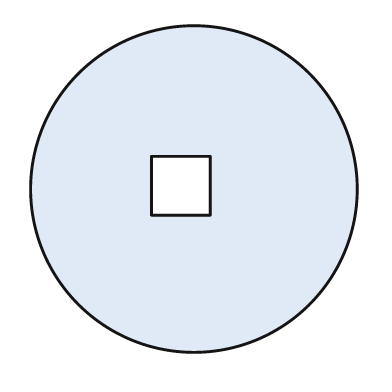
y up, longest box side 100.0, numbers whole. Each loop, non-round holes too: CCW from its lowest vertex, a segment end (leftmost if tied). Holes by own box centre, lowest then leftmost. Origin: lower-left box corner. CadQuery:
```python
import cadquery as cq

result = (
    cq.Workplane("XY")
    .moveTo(50.0, 50.0)
    .circle(50.0)
    .moveTo(37.0, 42.0)
    .lineTo(55.0, 42.0)
    .lineTo(55.0, 60.0)
    .lineTo(37.0, 60.0)
    .close()
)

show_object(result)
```